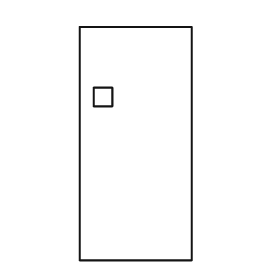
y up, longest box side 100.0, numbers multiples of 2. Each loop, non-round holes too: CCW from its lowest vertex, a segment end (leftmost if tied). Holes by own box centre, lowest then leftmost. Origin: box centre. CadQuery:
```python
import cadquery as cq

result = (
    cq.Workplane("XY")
    .moveTo(-24.0, -50.0)
    .lineTo(24.0, -50.0)
    .lineTo(24.0, 50.0)
    .lineTo(-24.0, 50.0)
    .close()
    .moveTo(-18.0, 16.0)
    .lineTo(-10.0, 16.0)
    .lineTo(-10.0, 24.0)
    .lineTo(-18.0, 24.0)
    .close()
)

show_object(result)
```